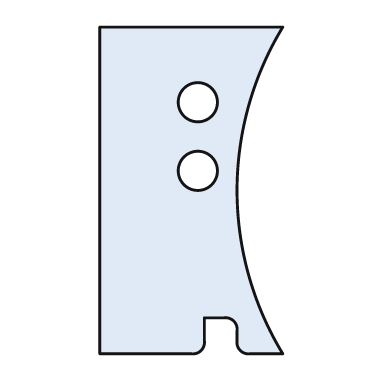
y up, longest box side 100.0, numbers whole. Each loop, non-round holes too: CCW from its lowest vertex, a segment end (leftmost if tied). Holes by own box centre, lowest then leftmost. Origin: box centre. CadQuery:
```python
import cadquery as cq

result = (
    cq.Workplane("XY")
    .moveTo(-28.0, -50.0)
    .lineTo(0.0, -50.0)
    .threePointArc((3.0, -49.0), (4.0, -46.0))
    .lineTo(4.0, -39.0)
    .lineTo(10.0, -39.0)
    .threePointArc((13.0, -40.0), (14.0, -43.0))
    .lineTo(14.0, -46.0)
    .threePointArc((15.0, -49.0), (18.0, -50.0))
    .lineTo(28.0, -50.0)
    .threePointArc((14.0, 0.0), (28.0, 50.0))
    .lineTo(-28.0, 50.0)
    .close()
    .moveTo(2.0, 6.0)
    .circle(6.0)
    .moveTo(2.0, 27.0)
    .circle(6.0)
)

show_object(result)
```